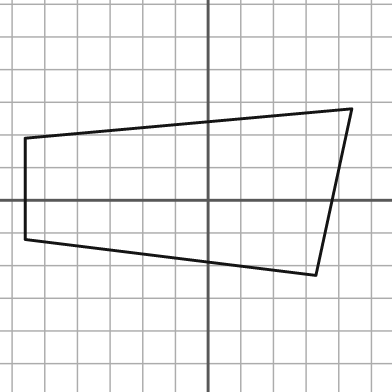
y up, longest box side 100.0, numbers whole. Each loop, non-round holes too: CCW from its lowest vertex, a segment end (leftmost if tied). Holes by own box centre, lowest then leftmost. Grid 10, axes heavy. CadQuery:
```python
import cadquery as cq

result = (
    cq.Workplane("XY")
    .moveTo(33.0, -23.0)
    .lineTo(44.0, 28.0)
    .lineTo(-56.0, 19.0)
    .lineTo(-56.0, -12.0)
    .close()
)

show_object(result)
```